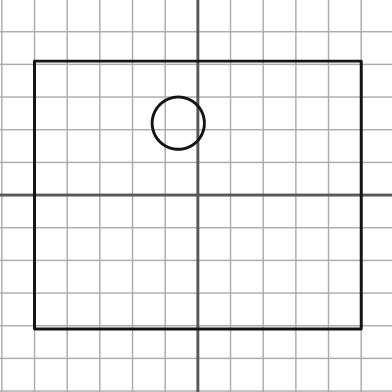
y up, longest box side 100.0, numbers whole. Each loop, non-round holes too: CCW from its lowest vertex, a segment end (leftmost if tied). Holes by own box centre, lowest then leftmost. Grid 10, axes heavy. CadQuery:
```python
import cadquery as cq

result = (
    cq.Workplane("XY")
    .moveTo(-50.0, -41.0)
    .lineTo(50.0, -41.0)
    .lineTo(50.0, 41.0)
    .lineTo(-50.0, 41.0)
    .close()
    .moveTo(-6.0, 22.0)
    .circle(8.0)
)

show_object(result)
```